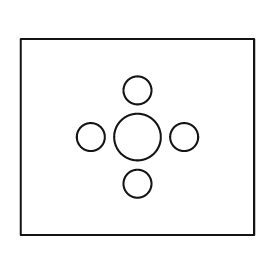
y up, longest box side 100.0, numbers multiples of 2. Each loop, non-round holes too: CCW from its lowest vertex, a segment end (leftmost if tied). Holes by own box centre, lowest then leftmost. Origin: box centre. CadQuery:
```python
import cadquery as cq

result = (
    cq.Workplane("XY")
    .moveTo(-50.0, -42.0)
    .lineTo(50.0, -42.0)
    .lineTo(50.0, 42.0)
    .lineTo(-50.0, 42.0)
    .close()
    .moveTo(0.0, -20.0)
    .circle(6.0)
    .moveTo(-20.0, 0.0)
    .circle(6.0)
    .moveTo(0.0, 0.0)
    .circle(10.0)
    .moveTo(20.0, 0.0)
    .circle(6.0)
    .moveTo(0.0, 20.0)
    .circle(6.0)
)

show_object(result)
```